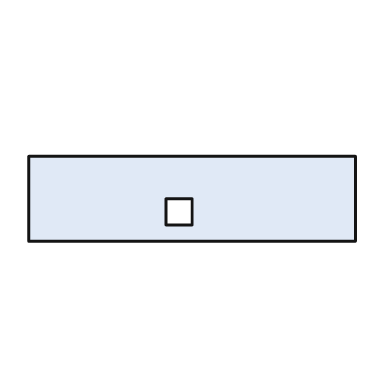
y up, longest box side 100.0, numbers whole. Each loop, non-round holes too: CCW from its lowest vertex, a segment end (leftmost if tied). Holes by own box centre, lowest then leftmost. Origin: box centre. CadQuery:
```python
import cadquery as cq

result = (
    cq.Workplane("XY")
    .moveTo(-50.0, -13.0)
    .lineTo(50.0, -13.0)
    .lineTo(50.0, 13.0)
    .lineTo(-50.0, 13.0)
    .close()
    .moveTo(-8.0, -8.0)
    .lineTo(0.0, -8.0)
    .lineTo(0.0, 0.0)
    .lineTo(-8.0, 0.0)
    .close()
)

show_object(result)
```